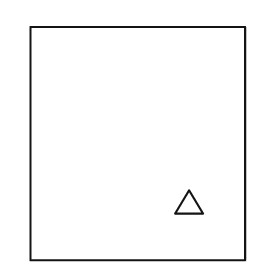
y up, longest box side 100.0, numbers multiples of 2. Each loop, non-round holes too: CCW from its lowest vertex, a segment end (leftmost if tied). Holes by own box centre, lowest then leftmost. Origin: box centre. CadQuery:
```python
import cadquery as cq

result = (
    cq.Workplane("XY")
    .moveTo(-46.0, -50.0)
    .lineTo(46.0, -50.0)
    .lineTo(46.0, 50.0)
    .lineTo(-46.0, 50.0)
    .close()
    .moveTo(16.0, -30.0)
    .lineTo(28.0, -30.0)
    .lineTo(22.0, -20.0)
    .close()
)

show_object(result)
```